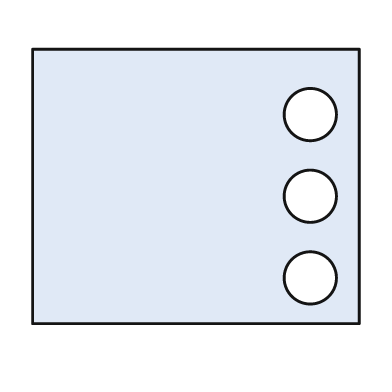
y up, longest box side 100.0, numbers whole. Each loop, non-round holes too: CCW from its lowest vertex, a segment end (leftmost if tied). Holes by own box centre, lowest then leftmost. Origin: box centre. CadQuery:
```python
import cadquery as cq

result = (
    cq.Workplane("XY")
    .moveTo(-50.0, -42.0)
    .lineTo(50.0, -42.0)
    .lineTo(50.0, 42.0)
    .lineTo(-50.0, 42.0)
    .close()
    .moveTo(35.0, -28.0)
    .circle(8.0)
    .moveTo(35.0, -3.0)
    .circle(8.0)
    .moveTo(35.0, 22.0)
    .circle(8.0)
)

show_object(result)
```